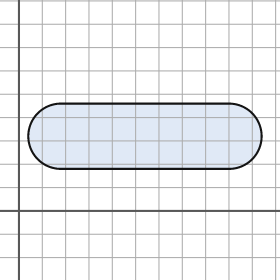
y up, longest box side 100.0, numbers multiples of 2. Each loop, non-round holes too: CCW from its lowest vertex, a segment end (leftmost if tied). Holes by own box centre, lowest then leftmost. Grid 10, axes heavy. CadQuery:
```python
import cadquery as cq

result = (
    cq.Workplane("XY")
    .moveTo(18.0, 18.0)
    .lineTo(90.0, 18.0)
    .threePointArc((104.0, 32.0), (90.0, 46.0))
    .lineTo(18.0, 46.0)
    .threePointArc((4.0, 32.0), (18.0, 18.0))
    .close()
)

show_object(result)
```